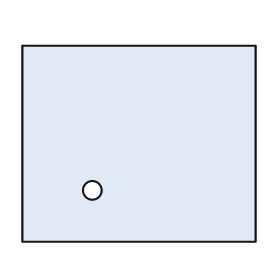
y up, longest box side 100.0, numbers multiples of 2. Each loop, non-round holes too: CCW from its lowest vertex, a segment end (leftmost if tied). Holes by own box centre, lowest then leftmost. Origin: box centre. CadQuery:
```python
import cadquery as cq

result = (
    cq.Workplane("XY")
    .moveTo(-50.0, -42.0)
    .lineTo(50.0, -42.0)
    .lineTo(50.0, 42.0)
    .lineTo(-50.0, 42.0)
    .close()
    .moveTo(-20.0, -20.0)
    .circle(4.0)
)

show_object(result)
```